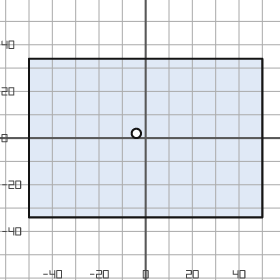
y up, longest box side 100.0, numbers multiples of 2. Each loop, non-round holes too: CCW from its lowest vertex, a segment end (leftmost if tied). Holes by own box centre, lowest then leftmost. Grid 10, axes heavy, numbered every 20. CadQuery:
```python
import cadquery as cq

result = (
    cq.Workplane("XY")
    .moveTo(-50.0, -34.0)
    .lineTo(50.0, -34.0)
    .lineTo(50.0, 34.0)
    .lineTo(-50.0, 34.0)
    .close()
    .moveTo(-4.0, 2.0)
    .circle(2.0)
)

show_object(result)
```